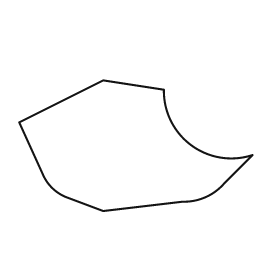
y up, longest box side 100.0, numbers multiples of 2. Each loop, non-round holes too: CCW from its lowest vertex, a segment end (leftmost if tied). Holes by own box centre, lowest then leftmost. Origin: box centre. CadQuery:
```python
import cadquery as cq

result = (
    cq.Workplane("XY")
    .moveTo(-14.0, -28.0)
    .lineTo(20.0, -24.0)
    .threePointArc((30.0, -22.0), (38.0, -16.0))
    .lineTo(50.0, -4.0)
    .threePointArc((24.0, 0.0), (12.0, 24.0))
    .lineTo(-14.0, 28.0)
    .lineTo(-50.0, 10.0)
    .lineTo(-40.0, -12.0)
    .threePointArc((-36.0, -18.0), (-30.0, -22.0))
    .close()
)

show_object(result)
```